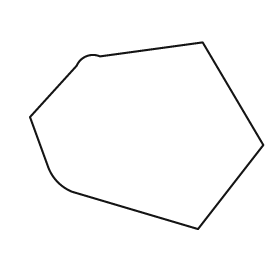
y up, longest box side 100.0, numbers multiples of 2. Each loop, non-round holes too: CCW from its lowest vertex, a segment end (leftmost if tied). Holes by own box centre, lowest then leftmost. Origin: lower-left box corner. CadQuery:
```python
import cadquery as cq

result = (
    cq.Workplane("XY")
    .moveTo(72.0, 0.0)
    .lineTo(100.0, 36.0)
    .lineTo(74.0, 80.0)
    .lineTo(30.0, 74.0)
    .threePointArc((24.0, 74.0), (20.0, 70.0))
    .lineTo(0.0, 48.0)
    .lineTo(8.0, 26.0)
    .threePointArc((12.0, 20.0), (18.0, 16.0))
    .close()
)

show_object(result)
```